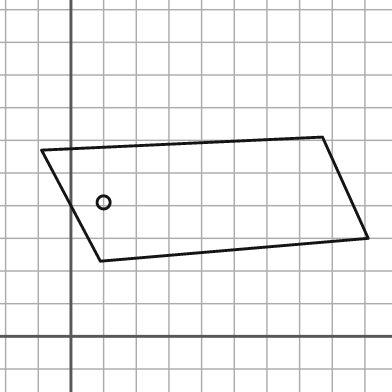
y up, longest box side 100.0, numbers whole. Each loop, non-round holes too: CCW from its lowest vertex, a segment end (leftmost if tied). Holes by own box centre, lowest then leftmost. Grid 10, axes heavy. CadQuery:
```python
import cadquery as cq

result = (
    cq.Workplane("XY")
    .moveTo(9.0, 23.0)
    .lineTo(91.0, 30.0)
    .lineTo(77.0, 61.0)
    .lineTo(-9.0, 57.0)
    .close()
    .moveTo(10.0, 41.0)
    .circle(2.0)
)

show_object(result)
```